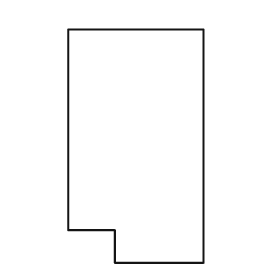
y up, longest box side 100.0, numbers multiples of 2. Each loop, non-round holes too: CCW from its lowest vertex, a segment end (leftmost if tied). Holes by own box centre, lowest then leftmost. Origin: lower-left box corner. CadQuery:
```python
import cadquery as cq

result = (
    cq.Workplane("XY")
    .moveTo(20.0, 0.0)
    .lineTo(58.0, 0.0)
    .lineTo(58.0, 100.0)
    .lineTo(0.0, 100.0)
    .lineTo(0.0, 14.0)
    .lineTo(20.0, 14.0)
    .close()
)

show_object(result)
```